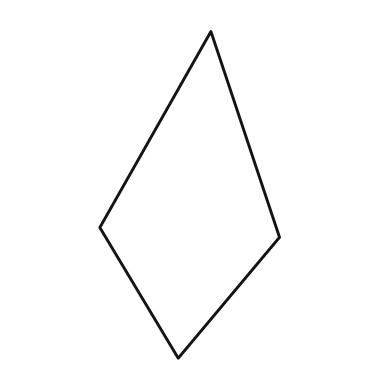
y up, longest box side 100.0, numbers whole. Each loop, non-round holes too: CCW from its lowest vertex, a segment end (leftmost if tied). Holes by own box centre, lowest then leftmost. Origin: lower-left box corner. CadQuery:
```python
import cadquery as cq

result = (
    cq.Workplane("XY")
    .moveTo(24.0, 0.0)
    .lineTo(55.0, 37.0)
    .lineTo(34.0, 100.0)
    .lineTo(0.0, 40.0)
    .close()
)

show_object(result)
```